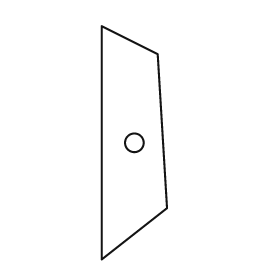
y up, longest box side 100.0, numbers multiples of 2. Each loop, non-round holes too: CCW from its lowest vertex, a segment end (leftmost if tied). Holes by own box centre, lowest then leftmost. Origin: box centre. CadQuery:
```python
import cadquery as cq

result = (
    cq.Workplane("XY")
    .moveTo(-14.0, -50.0)
    .lineTo(14.0, -28.0)
    .lineTo(10.0, 38.0)
    .lineTo(-14.0, 50.0)
    .close()
    .moveTo(0.0, 0.0)
    .circle(4.0)
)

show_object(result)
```